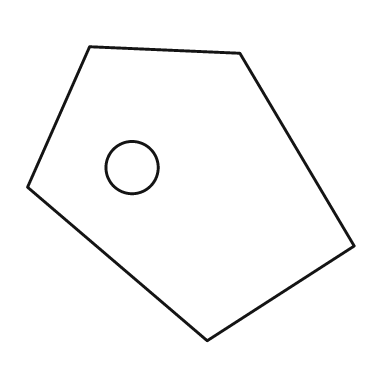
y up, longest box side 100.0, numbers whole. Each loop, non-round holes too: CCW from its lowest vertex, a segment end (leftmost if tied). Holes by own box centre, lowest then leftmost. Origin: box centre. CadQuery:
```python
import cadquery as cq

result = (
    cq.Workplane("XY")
    .moveTo(5.0, -45.0)
    .lineTo(50.0, -16.0)
    .lineTo(15.0, 43.0)
    .lineTo(-31.0, 45.0)
    .lineTo(-50.0, 2.0)
    .close()
    .moveTo(-18.0, 8.0)
    .circle(8.0)
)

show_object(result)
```